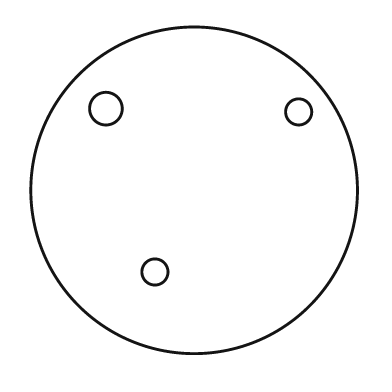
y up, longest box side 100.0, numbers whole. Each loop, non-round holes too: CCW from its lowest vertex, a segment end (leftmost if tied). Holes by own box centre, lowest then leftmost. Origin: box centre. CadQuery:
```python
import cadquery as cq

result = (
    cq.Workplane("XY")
    .moveTo(0.0, 0.0)
    .circle(50.0)
    .moveTo(-12.0, -25.0)
    .circle(4.0)
    .moveTo(32.0, 24.0)
    .circle(4.0)
    .moveTo(-27.0, 25.0)
    .circle(5.0)
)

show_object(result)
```